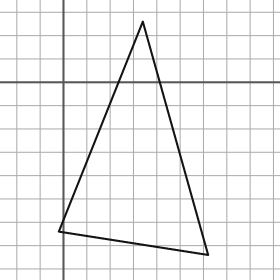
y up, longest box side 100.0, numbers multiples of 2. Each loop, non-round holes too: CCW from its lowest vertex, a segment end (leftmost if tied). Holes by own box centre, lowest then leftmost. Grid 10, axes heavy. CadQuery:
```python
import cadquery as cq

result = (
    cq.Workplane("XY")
    .moveTo(62.0, -74.0)
    .lineTo(34.0, 26.0)
    .lineTo(-2.0, -64.0)
    .close()
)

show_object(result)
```